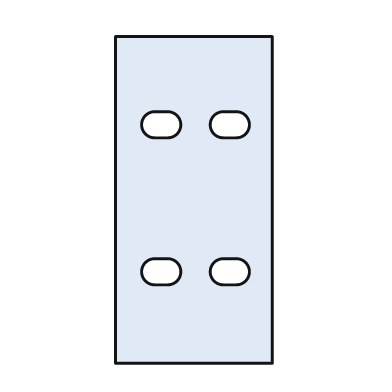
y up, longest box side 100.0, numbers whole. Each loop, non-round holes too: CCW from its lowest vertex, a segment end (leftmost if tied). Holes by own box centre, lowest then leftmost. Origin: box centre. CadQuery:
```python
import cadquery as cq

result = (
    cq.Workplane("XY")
    .moveTo(-24.0, -50.0)
    .lineTo(24.0, -50.0)
    .lineTo(24.0, 50.0)
    .lineTo(-24.0, 50.0)
    .close()
    .moveTo(-12.0, -26.0)
    .lineTo(-8.0, -26.0)
    .threePointArc((-4.0, -22.0), (-8.0, -18.0))
    .lineTo(-12.0, -18.0)
    .threePointArc((-16.0, -22.0), (-12.0, -26.0))
    .close()
    .moveTo(9.0, -26.0)
    .lineTo(13.0, -26.0)
    .threePointArc((17.0, -22.0), (13.0, -18.0))
    .lineTo(9.0, -18.0)
    .threePointArc((5.0, -22.0), (9.0, -26.0))
    .close()
    .moveTo(-12.0, 19.0)
    .lineTo(-8.0, 19.0)
    .threePointArc((-4.0, 23.0), (-8.0, 27.0))
    .lineTo(-12.0, 27.0)
    .threePointArc((-16.0, 23.0), (-12.0, 19.0))
    .close()
    .moveTo(9.0, 19.0)
    .lineTo(13.0, 19.0)
    .threePointArc((17.0, 23.0), (13.0, 27.0))
    .lineTo(9.0, 27.0)
    .threePointArc((5.0, 23.0), (9.0, 19.0))
    .close()
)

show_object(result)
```